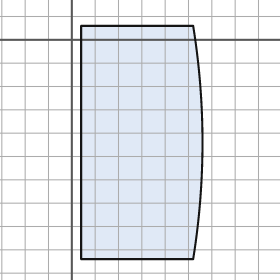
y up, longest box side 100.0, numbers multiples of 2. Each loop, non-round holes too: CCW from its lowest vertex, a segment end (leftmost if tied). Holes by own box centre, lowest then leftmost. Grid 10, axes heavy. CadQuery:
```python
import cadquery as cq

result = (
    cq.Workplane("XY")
    .moveTo(4.0, -94.0)
    .lineTo(52.0, -94.0)
    .threePointArc((56.0, -44.0), (52.0, 6.0))
    .lineTo(4.0, 6.0)
    .close()
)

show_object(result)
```